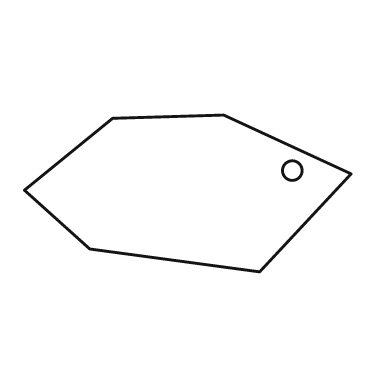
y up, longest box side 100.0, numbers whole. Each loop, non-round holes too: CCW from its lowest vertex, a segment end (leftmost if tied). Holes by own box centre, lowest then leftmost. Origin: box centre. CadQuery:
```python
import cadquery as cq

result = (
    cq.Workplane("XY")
    .moveTo(22.0, -24.0)
    .lineTo(50.0, 6.0)
    .lineTo(11.0, 24.0)
    .lineTo(-23.0, 23.0)
    .lineTo(-50.0, 1.0)
    .lineTo(-30.0, -17.0)
    .close()
    .moveTo(32.0, 7.0)
    .circle(3.0)
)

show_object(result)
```